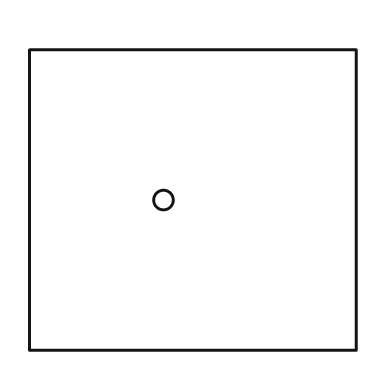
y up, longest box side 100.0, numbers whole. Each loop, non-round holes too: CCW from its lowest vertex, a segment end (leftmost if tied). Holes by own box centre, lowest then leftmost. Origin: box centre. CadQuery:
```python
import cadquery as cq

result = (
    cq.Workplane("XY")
    .moveTo(-50.0, -46.0)
    .lineTo(50.0, -46.0)
    .lineTo(50.0, 46.0)
    .lineTo(-50.0, 46.0)
    .close()
    .moveTo(-9.0, 0.0)
    .circle(3.0)
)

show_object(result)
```